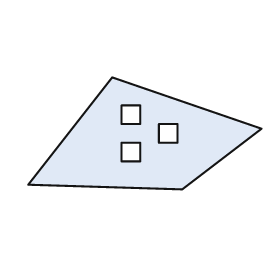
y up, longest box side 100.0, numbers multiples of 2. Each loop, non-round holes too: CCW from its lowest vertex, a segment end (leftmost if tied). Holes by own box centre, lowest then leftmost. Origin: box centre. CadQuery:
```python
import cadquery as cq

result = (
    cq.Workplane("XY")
    .moveTo(16.0, -24.0)
    .lineTo(50.0, 2.0)
    .lineTo(-14.0, 24.0)
    .lineTo(-50.0, -22.0)
    .close()
    .moveTo(-10.0, -12.0)
    .lineTo(-2.0, -12.0)
    .lineTo(-2.0, -4.0)
    .lineTo(-10.0, -4.0)
    .close()
    .moveTo(6.0, -4.0)
    .lineTo(14.0, -4.0)
    .lineTo(14.0, 4.0)
    .lineTo(6.0, 4.0)
    .close()
    .moveTo(-10.0, 4.0)
    .lineTo(-2.0, 4.0)
    .lineTo(-2.0, 12.0)
    .lineTo(-10.0, 12.0)
    .close()
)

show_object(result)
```